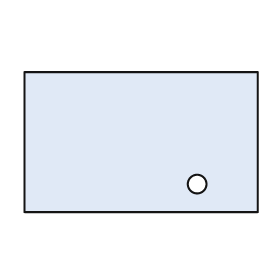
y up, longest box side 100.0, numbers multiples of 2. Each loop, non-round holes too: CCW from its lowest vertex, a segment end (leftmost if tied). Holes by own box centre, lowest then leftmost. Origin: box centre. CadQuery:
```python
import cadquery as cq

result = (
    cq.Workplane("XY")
    .moveTo(-50.0, -30.0)
    .lineTo(50.0, -30.0)
    .lineTo(50.0, 30.0)
    .lineTo(-50.0, 30.0)
    .close()
    .moveTo(24.0, -18.0)
    .circle(4.0)
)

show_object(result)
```